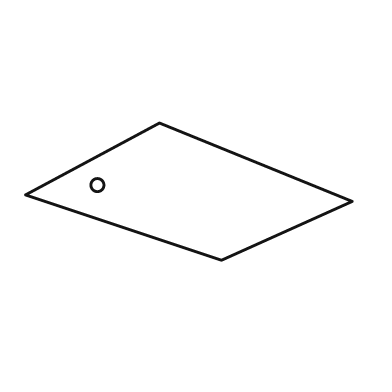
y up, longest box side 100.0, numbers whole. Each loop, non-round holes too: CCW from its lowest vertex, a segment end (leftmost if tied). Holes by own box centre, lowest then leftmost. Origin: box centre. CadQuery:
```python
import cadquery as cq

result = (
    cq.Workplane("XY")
    .moveTo(10.0, -21.0)
    .lineTo(50.0, -3.0)
    .lineTo(-9.0, 21.0)
    .lineTo(-50.0, -1.0)
    .close()
    .moveTo(-28.0, 2.0)
    .circle(2.0)
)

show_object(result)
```